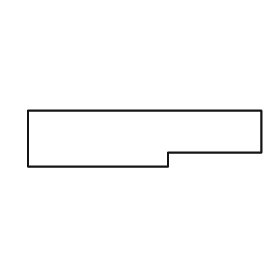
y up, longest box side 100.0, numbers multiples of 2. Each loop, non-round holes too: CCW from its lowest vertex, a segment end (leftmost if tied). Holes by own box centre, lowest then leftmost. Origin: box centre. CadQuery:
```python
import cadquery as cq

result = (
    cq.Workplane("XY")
    .moveTo(-50.0, -12.0)
    .lineTo(10.0, -12.0)
    .lineTo(10.0, -6.0)
    .lineTo(50.0, -6.0)
    .lineTo(50.0, 12.0)
    .lineTo(-50.0, 12.0)
    .close()
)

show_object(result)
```